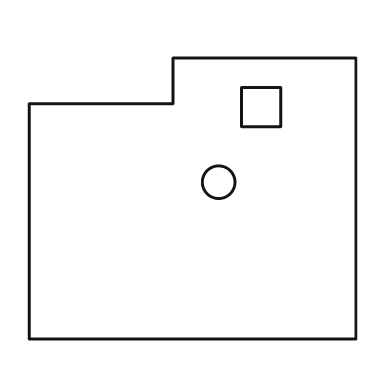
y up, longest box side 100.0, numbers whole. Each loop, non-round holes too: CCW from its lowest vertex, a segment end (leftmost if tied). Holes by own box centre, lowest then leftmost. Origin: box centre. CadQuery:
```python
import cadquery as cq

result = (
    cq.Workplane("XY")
    .moveTo(-50.0, -43.0)
    .lineTo(50.0, -43.0)
    .lineTo(50.0, 43.0)
    .lineTo(-6.0, 43.0)
    .lineTo(-6.0, 29.0)
    .lineTo(-50.0, 29.0)
    .close()
    .moveTo(8.0, 5.0)
    .circle(5.0)
    .moveTo(15.0, 22.0)
    .lineTo(27.0, 22.0)
    .lineTo(27.0, 34.0)
    .lineTo(15.0, 34.0)
    .close()
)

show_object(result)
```